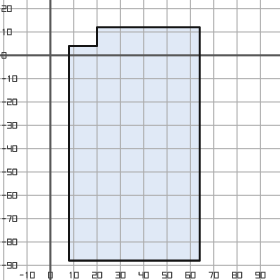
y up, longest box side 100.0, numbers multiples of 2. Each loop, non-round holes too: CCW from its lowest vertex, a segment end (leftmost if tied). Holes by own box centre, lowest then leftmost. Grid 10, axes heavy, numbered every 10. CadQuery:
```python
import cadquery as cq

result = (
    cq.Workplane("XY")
    .moveTo(8.0, -88.0)
    .lineTo(64.0, -88.0)
    .lineTo(64.0, 12.0)
    .lineTo(20.0, 12.0)
    .lineTo(20.0, 4.0)
    .lineTo(8.0, 4.0)
    .close()
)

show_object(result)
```